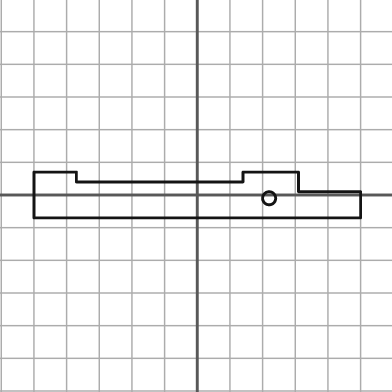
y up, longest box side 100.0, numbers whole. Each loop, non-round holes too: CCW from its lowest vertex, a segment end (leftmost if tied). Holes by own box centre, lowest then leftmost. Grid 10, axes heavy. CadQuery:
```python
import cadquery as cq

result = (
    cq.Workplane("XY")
    .moveTo(-50.0, -7.0)
    .lineTo(50.0, -7.0)
    .lineTo(50.0, 1.0)
    .lineTo(31.0, 1.0)
    .lineTo(31.0, 7.0)
    .lineTo(14.0, 7.0)
    .lineTo(14.0, 4.0)
    .lineTo(-37.0, 4.0)
    .lineTo(-37.0, 7.0)
    .lineTo(-50.0, 7.0)
    .close()
    .moveTo(22.0, -1.0)
    .circle(2.0)
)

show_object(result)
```